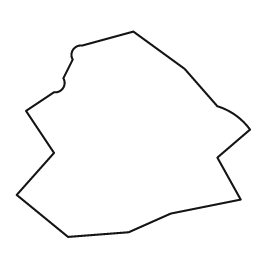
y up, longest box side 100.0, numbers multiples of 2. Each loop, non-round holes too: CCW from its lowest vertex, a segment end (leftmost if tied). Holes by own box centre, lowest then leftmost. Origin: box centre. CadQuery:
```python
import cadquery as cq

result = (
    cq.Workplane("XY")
    .moveTo(-28.0, -44.0)
    .lineTo(-2.0, -42.0)
    .lineTo(16.0, -34.0)
    .lineTo(46.0, -28.0)
    .lineTo(36.0, -10.0)
    .lineTo(50.0, 2.0)
    .threePointArc((44.0, 8.0), (36.0, 12.0))
    .lineTo(22.0, 28.0)
    .lineTo(0.0, 44.0)
    .lineTo(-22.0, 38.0)
    .threePointArc((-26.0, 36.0), (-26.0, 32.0))
    .lineTo(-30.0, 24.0)
    .threePointArc((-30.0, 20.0), (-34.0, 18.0))
    .lineTo(-46.0, 10.0)
    .lineTo(-34.0, -8.0)
    .lineTo(-50.0, -26.0)
    .close()
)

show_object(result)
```